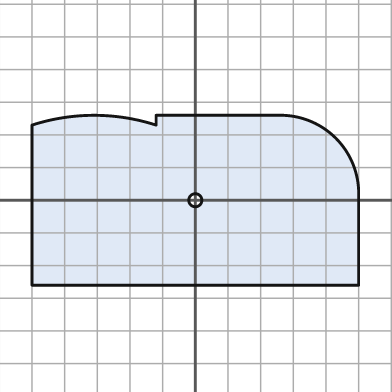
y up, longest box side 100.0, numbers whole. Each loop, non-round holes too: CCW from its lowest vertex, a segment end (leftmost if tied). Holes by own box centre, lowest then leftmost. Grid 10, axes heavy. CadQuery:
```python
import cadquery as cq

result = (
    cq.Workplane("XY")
    .moveTo(-50.0, -26.0)
    .lineTo(50.0, -26.0)
    .lineTo(50.0, 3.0)
    .threePointArc((43.0, 19.0), (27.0, 26.0))
    .lineTo(-12.0, 26.0)
    .lineTo(-12.0, 23.0)
    .threePointArc((-31.0, 26.0), (-50.0, 23.0))
    .close()
    .moveTo(0.0, 0.0)
    .circle(2.0)
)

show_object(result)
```